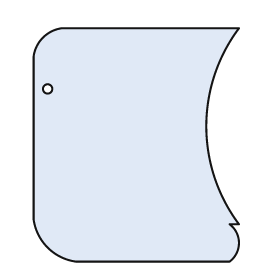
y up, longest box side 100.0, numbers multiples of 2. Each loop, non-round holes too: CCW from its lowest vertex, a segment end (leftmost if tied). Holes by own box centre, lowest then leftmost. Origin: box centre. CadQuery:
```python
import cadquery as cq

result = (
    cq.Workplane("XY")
    .moveTo(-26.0, -50.0)
    .lineTo(40.0, -50.0)
    .threePointArc((44.0, -42.0), (40.0, -34.0))
    .lineTo(44.0, -34.0)
    .threePointArc((30.0, 8.0), (44.0, 50.0))
    .lineTo(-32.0, 50.0)
    .threePointArc((-40.0, 46.0), (-44.0, 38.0))
    .lineTo(-44.0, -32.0)
    .threePointArc((-38.0, -44.0), (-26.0, -50.0))
    .close()
    .moveTo(-38.0, 24.0)
    .circle(2.0)
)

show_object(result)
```